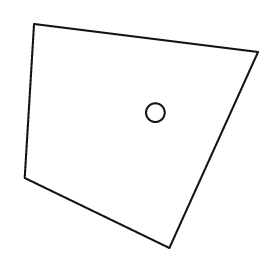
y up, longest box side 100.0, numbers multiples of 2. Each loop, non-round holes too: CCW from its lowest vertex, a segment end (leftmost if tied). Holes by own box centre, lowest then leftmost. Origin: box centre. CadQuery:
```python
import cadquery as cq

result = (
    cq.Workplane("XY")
    .moveTo(12.0, -48.0)
    .lineTo(50.0, 36.0)
    .lineTo(-46.0, 48.0)
    .lineTo(-50.0, -18.0)
    .close()
    .moveTo(6.0, 10.0)
    .circle(4.0)
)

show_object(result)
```